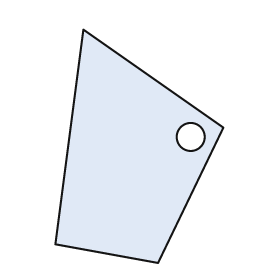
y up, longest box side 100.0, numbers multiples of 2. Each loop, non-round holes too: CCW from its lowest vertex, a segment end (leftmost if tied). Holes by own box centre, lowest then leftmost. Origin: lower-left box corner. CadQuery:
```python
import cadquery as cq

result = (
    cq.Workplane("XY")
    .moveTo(44.0, 0.0)
    .lineTo(72.0, 58.0)
    .lineTo(12.0, 100.0)
    .lineTo(0.0, 8.0)
    .close()
    .moveTo(58.0, 54.0)
    .circle(6.0)
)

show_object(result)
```